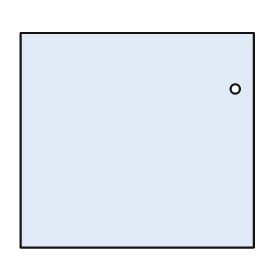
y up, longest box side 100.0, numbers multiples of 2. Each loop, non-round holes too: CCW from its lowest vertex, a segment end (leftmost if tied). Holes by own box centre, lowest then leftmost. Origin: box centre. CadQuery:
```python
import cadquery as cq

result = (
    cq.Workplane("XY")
    .moveTo(-50.0, -46.0)
    .lineTo(50.0, -46.0)
    .lineTo(50.0, 46.0)
    .lineTo(-50.0, 46.0)
    .close()
    .moveTo(42.0, 22.0)
    .circle(2.0)
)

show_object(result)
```